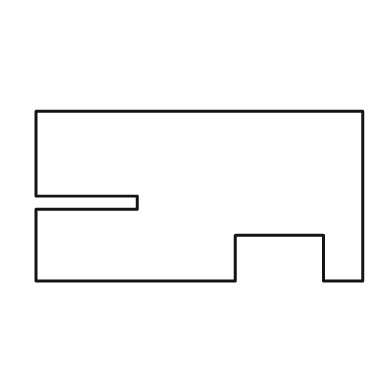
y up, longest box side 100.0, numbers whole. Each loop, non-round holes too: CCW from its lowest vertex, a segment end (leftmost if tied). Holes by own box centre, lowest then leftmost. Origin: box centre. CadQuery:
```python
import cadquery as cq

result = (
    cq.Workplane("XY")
    .moveTo(-50.0, -26.0)
    .lineTo(11.0, -26.0)
    .lineTo(11.0, -12.0)
    .lineTo(38.0, -12.0)
    .lineTo(38.0, -26.0)
    .lineTo(50.0, -26.0)
    .lineTo(50.0, 26.0)
    .lineTo(-50.0, 26.0)
    .lineTo(-50.0, 0.0)
    .lineTo(-19.0, 0.0)
    .lineTo(-19.0, -4.0)
    .lineTo(-50.0, -4.0)
    .close()
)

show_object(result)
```